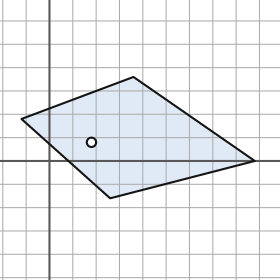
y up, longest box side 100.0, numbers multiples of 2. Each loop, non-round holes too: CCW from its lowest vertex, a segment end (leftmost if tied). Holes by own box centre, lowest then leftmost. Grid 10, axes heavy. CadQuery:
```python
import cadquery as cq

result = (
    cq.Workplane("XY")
    .moveTo(26.0, -16.0)
    .lineTo(88.0, 0.0)
    .lineTo(36.0, 36.0)
    .lineTo(-12.0, 18.0)
    .close()
    .moveTo(18.0, 8.0)
    .circle(2.0)
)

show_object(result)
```